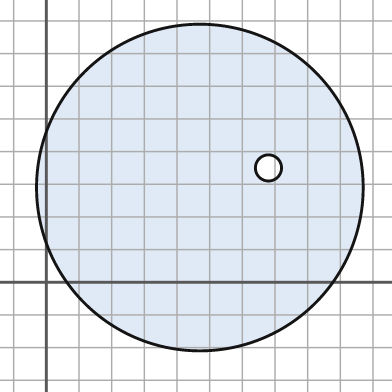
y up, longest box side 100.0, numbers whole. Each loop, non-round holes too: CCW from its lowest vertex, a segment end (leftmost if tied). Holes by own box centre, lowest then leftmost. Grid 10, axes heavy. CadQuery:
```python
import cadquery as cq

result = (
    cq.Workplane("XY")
    .moveTo(47.0, 29.0)
    .circle(50.0)
    .moveTo(68.0, 35.0)
    .circle(4.0)
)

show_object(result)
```